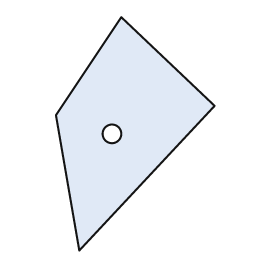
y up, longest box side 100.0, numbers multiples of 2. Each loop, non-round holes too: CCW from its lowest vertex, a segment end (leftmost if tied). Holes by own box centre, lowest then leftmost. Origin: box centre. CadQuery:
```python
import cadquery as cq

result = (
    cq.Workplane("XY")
    .moveTo(-24.0, -50.0)
    .lineTo(34.0, 12.0)
    .lineTo(-6.0, 50.0)
    .lineTo(-34.0, 8.0)
    .close()
    .moveTo(-10.0, 0.0)
    .circle(4.0)
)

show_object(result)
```